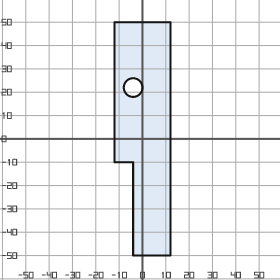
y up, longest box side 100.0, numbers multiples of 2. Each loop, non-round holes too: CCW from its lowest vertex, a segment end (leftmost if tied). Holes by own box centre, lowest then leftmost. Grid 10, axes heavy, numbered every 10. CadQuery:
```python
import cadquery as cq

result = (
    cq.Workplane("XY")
    .moveTo(-4.0, -50.0)
    .lineTo(12.0, -50.0)
    .lineTo(12.0, 50.0)
    .lineTo(-12.0, 50.0)
    .lineTo(-12.0, -10.0)
    .lineTo(-4.0, -10.0)
    .close()
    .moveTo(-4.0, 22.0)
    .circle(4.0)
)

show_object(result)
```